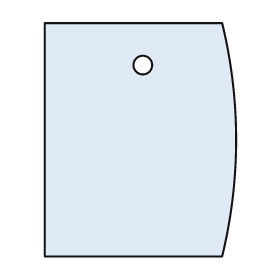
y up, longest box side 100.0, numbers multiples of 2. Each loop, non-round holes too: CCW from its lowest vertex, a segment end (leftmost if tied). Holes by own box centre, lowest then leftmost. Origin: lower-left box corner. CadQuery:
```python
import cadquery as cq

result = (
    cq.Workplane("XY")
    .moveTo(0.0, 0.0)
    .lineTo(76.0, 0.0)
    .threePointArc((82.0, 50.0), (76.0, 100.0))
    .lineTo(0.0, 100.0)
    .close()
    .moveTo(42.0, 82.0)
    .circle(4.0)
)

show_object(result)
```